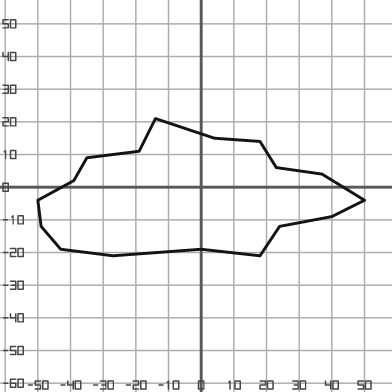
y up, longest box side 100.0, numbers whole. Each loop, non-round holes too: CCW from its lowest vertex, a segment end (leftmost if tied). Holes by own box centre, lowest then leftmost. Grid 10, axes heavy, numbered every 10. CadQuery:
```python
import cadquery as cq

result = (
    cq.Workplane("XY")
    .moveTo(-27.0, -21.0)
    .lineTo(0.0, -19.0)
    .lineTo(18.0, -21.0)
    .lineTo(24.0, -12.0)
    .lineTo(40.0, -9.0)
    .lineTo(50.0, -4.0)
    .lineTo(37.0, 4.0)
    .lineTo(23.0, 6.0)
    .lineTo(18.0, 14.0)
    .lineTo(4.0, 15.0)
    .lineTo(-14.0, 21.0)
    .lineTo(-19.0, 11.0)
    .lineTo(-35.0, 9.0)
    .lineTo(-39.0, 2.0)
    .lineTo(-50.0, -4.0)
    .lineTo(-49.0, -12.0)
    .lineTo(-43.0, -19.0)
    .close()
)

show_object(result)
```